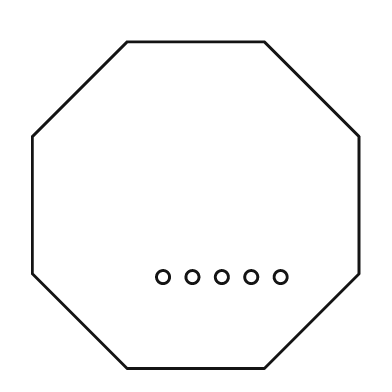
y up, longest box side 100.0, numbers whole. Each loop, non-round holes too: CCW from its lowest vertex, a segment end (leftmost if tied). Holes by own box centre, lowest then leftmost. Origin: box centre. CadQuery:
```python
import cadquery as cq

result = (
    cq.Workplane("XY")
    .moveTo(-21.0, -50.0)
    .lineTo(21.0, -50.0)
    .lineTo(50.0, -21.0)
    .lineTo(50.0, 21.0)
    .lineTo(21.0, 50.0)
    .lineTo(-21.0, 50.0)
    .lineTo(-50.0, 21.0)
    .lineTo(-50.0, -21.0)
    .close()
    .moveTo(-10.0, -22.0)
    .circle(2.0)
    .moveTo(-1.0, -22.0)
    .circle(2.0)
    .moveTo(8.0, -22.0)
    .circle(2.0)
    .moveTo(17.0, -22.0)
    .circle(2.0)
    .moveTo(26.0, -22.0)
    .circle(2.0)
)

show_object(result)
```